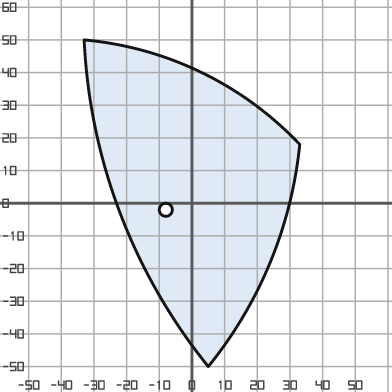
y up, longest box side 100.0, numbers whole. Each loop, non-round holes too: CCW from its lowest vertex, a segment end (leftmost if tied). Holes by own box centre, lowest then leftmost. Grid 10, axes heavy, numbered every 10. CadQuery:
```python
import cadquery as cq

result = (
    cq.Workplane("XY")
    .moveTo(5.0, -50.0)
    .threePointArc((24.0, -18.0), (33.0, 18.0))
    .threePointArc((3.0, 40.0), (-33.0, 50.0))
    .threePointArc((-22.0, -3.0), (5.0, -50.0))
    .close()
    .moveTo(-8.0, -2.0)
    .circle(2.0)
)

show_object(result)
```